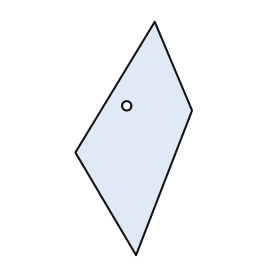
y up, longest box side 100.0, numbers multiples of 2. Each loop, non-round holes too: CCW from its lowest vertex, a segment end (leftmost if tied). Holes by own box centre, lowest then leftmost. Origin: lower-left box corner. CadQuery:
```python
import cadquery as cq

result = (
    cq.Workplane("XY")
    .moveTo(26.0, 0.0)
    .lineTo(50.0, 62.0)
    .lineTo(34.0, 100.0)
    .lineTo(0.0, 44.0)
    .close()
    .moveTo(22.0, 64.0)
    .circle(2.0)
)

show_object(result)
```